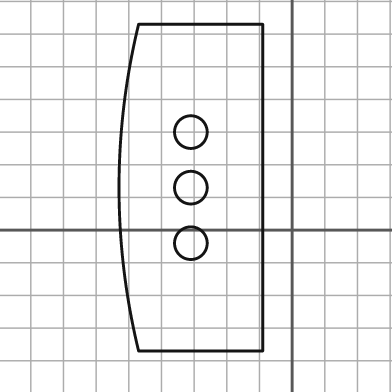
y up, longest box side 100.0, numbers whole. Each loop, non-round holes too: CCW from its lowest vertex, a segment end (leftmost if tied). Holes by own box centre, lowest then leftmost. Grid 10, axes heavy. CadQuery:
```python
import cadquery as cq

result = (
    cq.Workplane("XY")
    .moveTo(-47.0, -37.0)
    .lineTo(-9.0, -37.0)
    .lineTo(-9.0, 63.0)
    .lineTo(-47.0, 63.0)
    .threePointArc((-53.0, 13.0), (-47.0, -37.0))
    .close()
    .moveTo(-31.0, -4.0)
    .circle(5.0)
    .moveTo(-31.0, 13.0)
    .circle(5.0)
    .moveTo(-31.0, 30.0)
    .circle(5.0)
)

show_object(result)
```